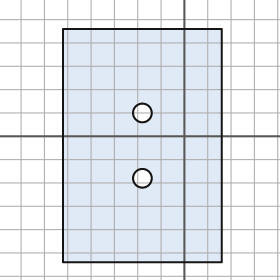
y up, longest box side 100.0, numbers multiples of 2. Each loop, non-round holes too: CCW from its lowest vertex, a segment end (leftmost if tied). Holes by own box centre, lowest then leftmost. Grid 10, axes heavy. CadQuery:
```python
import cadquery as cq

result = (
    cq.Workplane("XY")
    .moveTo(-52.0, -54.0)
    .lineTo(16.0, -54.0)
    .lineTo(16.0, 46.0)
    .lineTo(-52.0, 46.0)
    .close()
    .moveTo(-18.0, -18.0)
    .circle(4.0)
    .moveTo(-18.0, 10.0)
    .circle(4.0)
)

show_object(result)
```